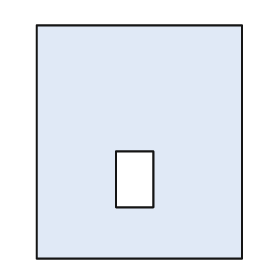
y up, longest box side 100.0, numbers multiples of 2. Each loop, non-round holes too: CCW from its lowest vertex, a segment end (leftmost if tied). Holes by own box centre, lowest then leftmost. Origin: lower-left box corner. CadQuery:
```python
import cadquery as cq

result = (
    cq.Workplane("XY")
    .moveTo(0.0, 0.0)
    .lineTo(88.0, 0.0)
    .lineTo(88.0, 100.0)
    .lineTo(0.0, 100.0)
    .close()
    .moveTo(34.0, 22.0)
    .lineTo(50.0, 22.0)
    .lineTo(50.0, 46.0)
    .lineTo(34.0, 46.0)
    .close()
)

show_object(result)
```